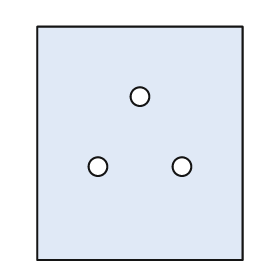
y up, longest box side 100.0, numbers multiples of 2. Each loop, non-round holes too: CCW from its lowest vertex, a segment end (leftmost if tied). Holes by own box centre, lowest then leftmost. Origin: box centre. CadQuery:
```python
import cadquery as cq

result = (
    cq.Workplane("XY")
    .moveTo(-44.0, -50.0)
    .lineTo(44.0, -50.0)
    .lineTo(44.0, 50.0)
    .lineTo(-44.0, 50.0)
    .close()
    .moveTo(-18.0, -10.0)
    .circle(4.0)
    .moveTo(18.0, -10.0)
    .circle(4.0)
    .moveTo(0.0, 20.0)
    .circle(4.0)
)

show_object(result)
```